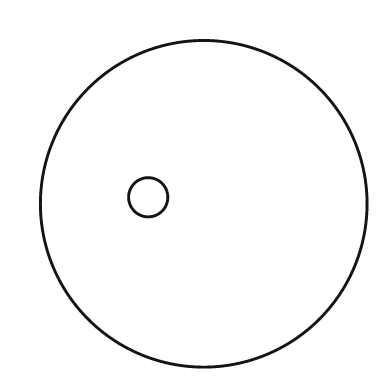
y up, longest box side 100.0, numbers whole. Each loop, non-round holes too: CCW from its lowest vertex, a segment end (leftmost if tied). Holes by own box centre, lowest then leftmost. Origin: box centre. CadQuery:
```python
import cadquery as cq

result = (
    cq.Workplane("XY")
    .moveTo(0.0, 0.0)
    .circle(50.0)
    .moveTo(-17.0, 2.0)
    .circle(6.0)
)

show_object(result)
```